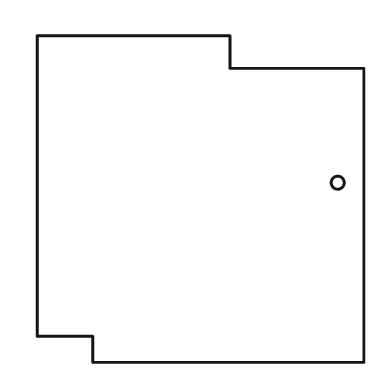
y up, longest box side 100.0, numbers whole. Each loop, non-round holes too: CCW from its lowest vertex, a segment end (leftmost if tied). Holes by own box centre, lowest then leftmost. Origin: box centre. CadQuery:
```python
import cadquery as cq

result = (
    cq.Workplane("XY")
    .moveTo(-33.0, -50.0)
    .lineTo(50.0, -50.0)
    .lineTo(50.0, 40.0)
    .lineTo(9.0, 40.0)
    .lineTo(9.0, 50.0)
    .lineTo(-50.0, 50.0)
    .lineTo(-50.0, -42.0)
    .lineTo(-33.0, -42.0)
    .close()
    .moveTo(42.0, 5.0)
    .circle(2.0)
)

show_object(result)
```